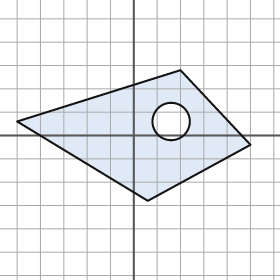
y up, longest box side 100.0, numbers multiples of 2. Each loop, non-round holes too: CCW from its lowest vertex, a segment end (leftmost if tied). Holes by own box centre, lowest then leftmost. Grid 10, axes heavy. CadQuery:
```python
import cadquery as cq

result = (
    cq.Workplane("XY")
    .moveTo(6.0, -28.0)
    .lineTo(50.0, -4.0)
    .lineTo(20.0, 28.0)
    .lineTo(-50.0, 6.0)
    .close()
    .moveTo(16.0, 6.0)
    .circle(8.0)
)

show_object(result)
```